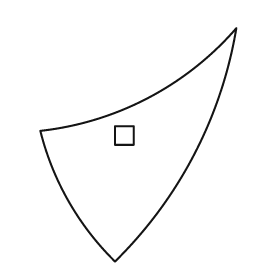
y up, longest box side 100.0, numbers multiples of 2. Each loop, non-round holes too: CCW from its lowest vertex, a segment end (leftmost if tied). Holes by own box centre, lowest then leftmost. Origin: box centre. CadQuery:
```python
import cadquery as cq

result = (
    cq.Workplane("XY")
    .moveTo(-10.0, -50.0)
    .threePointArc((24.0, -4.0), (42.0, 50.0))
    .threePointArc((4.0, 20.0), (-42.0, 6.0))
    .threePointArc((-30.0, -24.0), (-10.0, -50.0))
    .close()
    .moveTo(-10.0, 0.0)
    .lineTo(-2.0, 0.0)
    .lineTo(-2.0, 8.0)
    .lineTo(-10.0, 8.0)
    .close()
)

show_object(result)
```